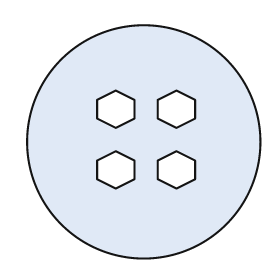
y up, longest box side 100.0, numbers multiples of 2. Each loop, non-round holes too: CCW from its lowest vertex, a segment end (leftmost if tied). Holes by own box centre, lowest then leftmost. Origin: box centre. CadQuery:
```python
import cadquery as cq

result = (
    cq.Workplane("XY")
    .moveTo(0.0, 0.0)
    .circle(50.0)
    .moveTo(-12.0, -20.0)
    .lineTo(-4.0, -16.0)
    .lineTo(-4.0, -8.0)
    .lineTo(-12.0, -4.0)
    .lineTo(-20.0, -8.0)
    .lineTo(-20.0, -16.0)
    .close()
    .moveTo(14.0, -20.0)
    .lineTo(22.0, -16.0)
    .lineTo(22.0, -8.0)
    .lineTo(14.0, -4.0)
    .lineTo(6.0, -8.0)
    .lineTo(6.0, -16.0)
    .close()
    .moveTo(-12.0, 6.0)
    .lineTo(-4.0, 10.0)
    .lineTo(-4.0, 18.0)
    .lineTo(-12.0, 22.0)
    .lineTo(-20.0, 18.0)
    .lineTo(-20.0, 10.0)
    .close()
    .moveTo(14.0, 6.0)
    .lineTo(22.0, 10.0)
    .lineTo(22.0, 18.0)
    .lineTo(14.0, 22.0)
    .lineTo(6.0, 18.0)
    .lineTo(6.0, 10.0)
    .close()
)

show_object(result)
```